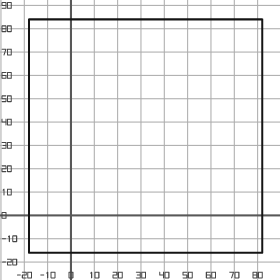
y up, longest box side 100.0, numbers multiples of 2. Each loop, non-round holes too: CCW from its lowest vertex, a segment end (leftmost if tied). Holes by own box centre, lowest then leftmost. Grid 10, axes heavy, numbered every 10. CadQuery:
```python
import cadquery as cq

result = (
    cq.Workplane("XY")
    .moveTo(-18.0, -16.0)
    .lineTo(82.0, -16.0)
    .lineTo(82.0, 84.0)
    .lineTo(-18.0, 84.0)
    .close()
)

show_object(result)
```